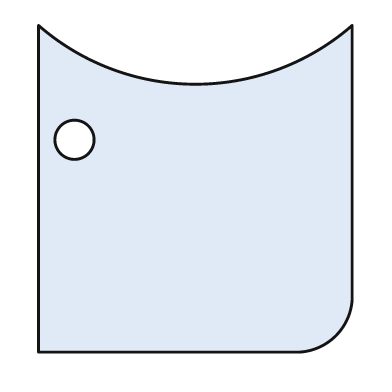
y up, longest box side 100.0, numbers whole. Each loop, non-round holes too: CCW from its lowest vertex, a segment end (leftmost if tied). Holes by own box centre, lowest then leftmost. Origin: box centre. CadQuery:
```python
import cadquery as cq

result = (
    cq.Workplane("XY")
    .moveTo(-48.0, -50.0)
    .lineTo(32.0, -50.0)
    .threePointArc((43.0, -45.0), (48.0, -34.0))
    .lineTo(48.0, 50.0)
    .threePointArc((0.0, 32.0), (-48.0, 50.0))
    .close()
    .moveTo(-37.0, 15.0)
    .circle(6.0)
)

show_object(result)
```